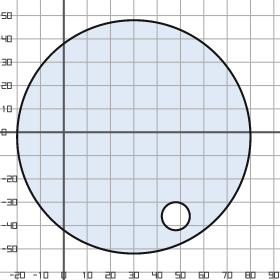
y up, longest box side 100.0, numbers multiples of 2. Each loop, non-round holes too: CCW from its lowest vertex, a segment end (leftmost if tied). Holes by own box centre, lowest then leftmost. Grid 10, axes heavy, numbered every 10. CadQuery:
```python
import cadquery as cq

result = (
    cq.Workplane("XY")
    .moveTo(30.0, -2.0)
    .circle(50.0)
    .moveTo(48.0, -36.0)
    .circle(6.0)
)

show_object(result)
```